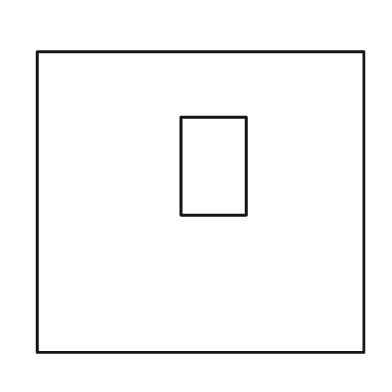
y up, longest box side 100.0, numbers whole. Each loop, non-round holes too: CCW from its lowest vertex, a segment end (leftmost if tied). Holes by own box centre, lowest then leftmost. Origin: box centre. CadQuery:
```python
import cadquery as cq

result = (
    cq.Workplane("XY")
    .moveTo(-50.0, -46.0)
    .lineTo(50.0, -46.0)
    .lineTo(50.0, 46.0)
    .lineTo(-50.0, 46.0)
    .close()
    .moveTo(-6.0, -4.0)
    .lineTo(14.0, -4.0)
    .lineTo(14.0, 26.0)
    .lineTo(-6.0, 26.0)
    .close()
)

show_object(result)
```